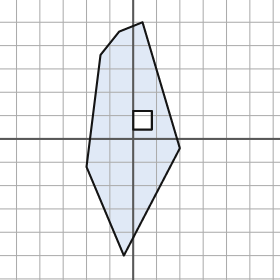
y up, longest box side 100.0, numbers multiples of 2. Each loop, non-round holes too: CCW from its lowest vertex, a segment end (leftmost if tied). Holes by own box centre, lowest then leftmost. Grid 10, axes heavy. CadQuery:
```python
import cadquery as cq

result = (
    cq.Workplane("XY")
    .moveTo(-4.0, -50.0)
    .lineTo(20.0, -4.0)
    .lineTo(4.0, 50.0)
    .lineTo(-6.0, 46.0)
    .lineTo(-14.0, 36.0)
    .lineTo(-20.0, -12.0)
    .close()
    .moveTo(0.0, 4.0)
    .lineTo(8.0, 4.0)
    .lineTo(8.0, 12.0)
    .lineTo(0.0, 12.0)
    .close()
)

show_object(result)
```